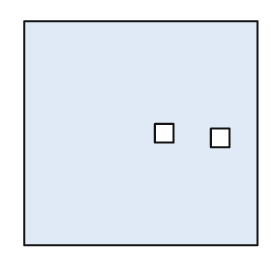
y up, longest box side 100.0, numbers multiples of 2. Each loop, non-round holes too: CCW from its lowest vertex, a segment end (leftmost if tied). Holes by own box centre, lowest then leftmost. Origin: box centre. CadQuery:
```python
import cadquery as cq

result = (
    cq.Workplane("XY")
    .moveTo(-50.0, -48.0)
    .lineTo(50.0, -48.0)
    .lineTo(50.0, 48.0)
    .lineTo(-50.0, 48.0)
    .close()
    .moveTo(30.0, -6.0)
    .lineTo(38.0, -6.0)
    .lineTo(38.0, 2.0)
    .lineTo(30.0, 2.0)
    .close()
    .moveTo(6.0, -4.0)
    .lineTo(14.0, -4.0)
    .lineTo(14.0, 4.0)
    .lineTo(6.0, 4.0)
    .close()
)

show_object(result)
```